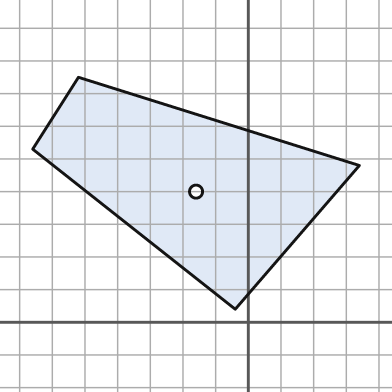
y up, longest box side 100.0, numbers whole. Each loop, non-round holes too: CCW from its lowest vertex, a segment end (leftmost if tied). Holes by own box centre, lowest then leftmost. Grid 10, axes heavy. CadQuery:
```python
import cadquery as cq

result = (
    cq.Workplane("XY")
    .moveTo(-4.0, 4.0)
    .lineTo(34.0, 48.0)
    .lineTo(-52.0, 75.0)
    .lineTo(-66.0, 53.0)
    .close()
    .moveTo(-16.0, 40.0)
    .circle(2.0)
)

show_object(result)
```